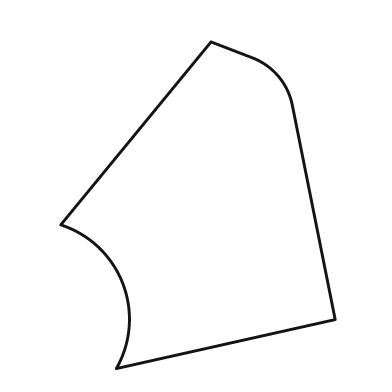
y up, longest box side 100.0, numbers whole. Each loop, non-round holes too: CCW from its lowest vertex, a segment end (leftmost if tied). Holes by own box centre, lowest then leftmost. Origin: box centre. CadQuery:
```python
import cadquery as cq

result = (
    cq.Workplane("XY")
    .moveTo(-25.0, -50.0)
    .lineTo(42.0, -35.0)
    .lineTo(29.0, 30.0)
    .threePointArc((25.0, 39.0), (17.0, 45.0))
    .lineTo(4.0, 50.0)
    .lineTo(-42.0, -6.0)
    .threePointArc((-23.0, -24.0), (-25.0, -50.0))
    .close()
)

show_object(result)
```